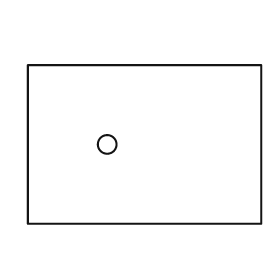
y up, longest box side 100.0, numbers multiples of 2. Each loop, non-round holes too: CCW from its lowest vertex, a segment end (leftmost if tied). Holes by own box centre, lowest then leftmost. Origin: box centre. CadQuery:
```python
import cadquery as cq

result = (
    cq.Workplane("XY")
    .moveTo(-50.0, -34.0)
    .lineTo(50.0, -34.0)
    .lineTo(50.0, 34.0)
    .lineTo(-50.0, 34.0)
    .close()
    .moveTo(-16.0, 0.0)
    .circle(4.0)
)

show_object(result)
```